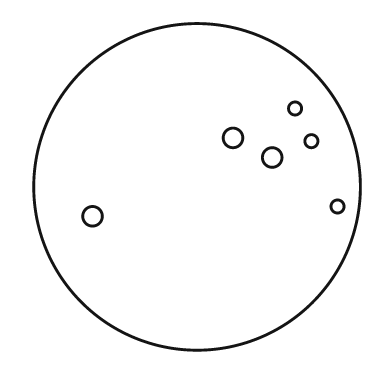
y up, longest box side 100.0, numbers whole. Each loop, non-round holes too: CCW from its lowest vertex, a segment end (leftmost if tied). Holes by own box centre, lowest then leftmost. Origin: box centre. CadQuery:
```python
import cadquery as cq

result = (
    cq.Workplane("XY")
    .moveTo(0.0, 0.0)
    .circle(50.0)
    .moveTo(-32.0, -9.0)
    .circle(3.0)
    .moveTo(43.0, -6.0)
    .circle(2.0)
    .moveTo(23.0, 9.0)
    .circle(3.0)
    .moveTo(35.0, 14.0)
    .circle(2.0)
    .moveTo(11.0, 15.0)
    .circle(3.0)
    .moveTo(30.0, 24.0)
    .circle(2.0)
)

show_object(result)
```